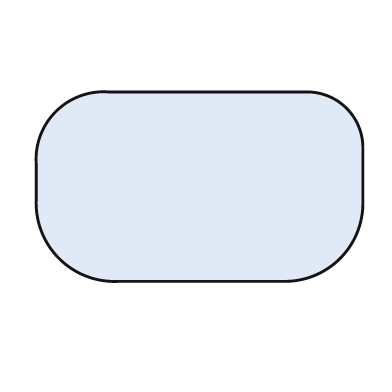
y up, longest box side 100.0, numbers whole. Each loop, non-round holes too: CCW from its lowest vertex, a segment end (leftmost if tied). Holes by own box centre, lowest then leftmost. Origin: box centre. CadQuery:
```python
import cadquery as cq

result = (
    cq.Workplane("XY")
    .moveTo(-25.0, -29.0)
    .lineTo(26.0, -29.0)
    .threePointArc((43.0, -22.0), (50.0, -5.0))
    .lineTo(50.0, 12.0)
    .threePointArc((45.0, 24.0), (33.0, 29.0))
    .lineTo(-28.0, 29.0)
    .threePointArc((-44.0, 23.0), (-50.0, 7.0))
    .lineTo(-50.0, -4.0)
    .threePointArc((-43.0, -22.0), (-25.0, -29.0))
    .close()
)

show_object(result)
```